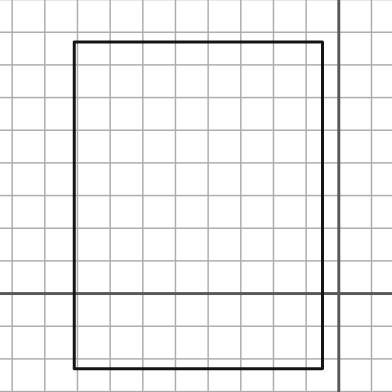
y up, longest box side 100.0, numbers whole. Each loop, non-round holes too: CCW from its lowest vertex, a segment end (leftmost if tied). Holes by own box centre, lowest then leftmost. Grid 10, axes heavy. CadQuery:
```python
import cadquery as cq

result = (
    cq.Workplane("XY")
    .moveTo(-81.0, -23.0)
    .lineTo(-5.0, -23.0)
    .lineTo(-5.0, 77.0)
    .lineTo(-81.0, 77.0)
    .close()
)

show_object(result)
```